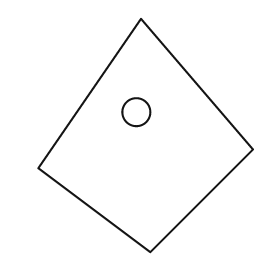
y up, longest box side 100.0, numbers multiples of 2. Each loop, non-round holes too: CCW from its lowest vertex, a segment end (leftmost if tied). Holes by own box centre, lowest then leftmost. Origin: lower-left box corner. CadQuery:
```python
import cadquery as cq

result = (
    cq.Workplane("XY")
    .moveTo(48.0, 0.0)
    .lineTo(92.0, 44.0)
    .lineTo(44.0, 100.0)
    .lineTo(0.0, 36.0)
    .close()
    .moveTo(42.0, 60.0)
    .circle(6.0)
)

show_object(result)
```